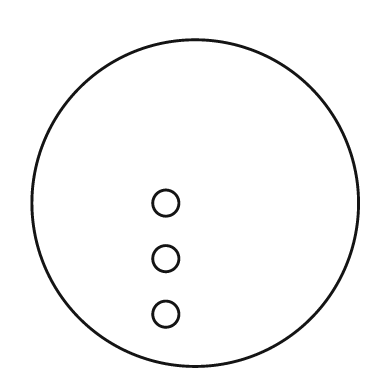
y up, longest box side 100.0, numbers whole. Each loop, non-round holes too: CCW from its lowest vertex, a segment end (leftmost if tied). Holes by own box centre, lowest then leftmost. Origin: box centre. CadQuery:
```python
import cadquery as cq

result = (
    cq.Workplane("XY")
    .moveTo(0.0, 0.0)
    .circle(50.0)
    .moveTo(-9.0, -34.0)
    .circle(4.0)
    .moveTo(-9.0, -17.0)
    .circle(4.0)
    .moveTo(-9.0, 0.0)
    .circle(4.0)
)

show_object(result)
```